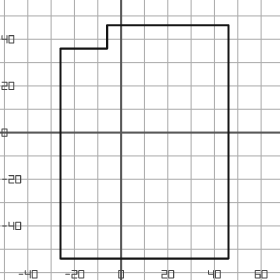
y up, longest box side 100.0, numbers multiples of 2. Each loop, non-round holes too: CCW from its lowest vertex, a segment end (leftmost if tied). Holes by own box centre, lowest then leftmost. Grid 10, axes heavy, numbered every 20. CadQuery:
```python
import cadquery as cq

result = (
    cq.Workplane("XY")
    .moveTo(-26.0, -54.0)
    .lineTo(46.0, -54.0)
    .lineTo(46.0, 46.0)
    .lineTo(-6.0, 46.0)
    .lineTo(-6.0, 36.0)
    .lineTo(-26.0, 36.0)
    .close()
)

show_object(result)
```